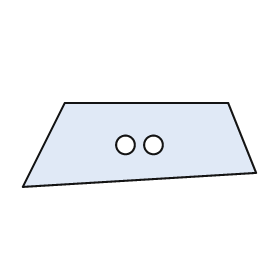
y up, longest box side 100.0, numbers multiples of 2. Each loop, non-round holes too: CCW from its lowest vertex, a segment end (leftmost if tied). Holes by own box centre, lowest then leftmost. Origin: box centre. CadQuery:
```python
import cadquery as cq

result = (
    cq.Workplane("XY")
    .moveTo(-50.0, -18.0)
    .lineTo(50.0, -12.0)
    .lineTo(38.0, 18.0)
    .lineTo(-32.0, 18.0)
    .close()
    .moveTo(-6.0, 0.0)
    .circle(4.0)
    .moveTo(6.0, 0.0)
    .circle(4.0)
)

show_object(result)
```